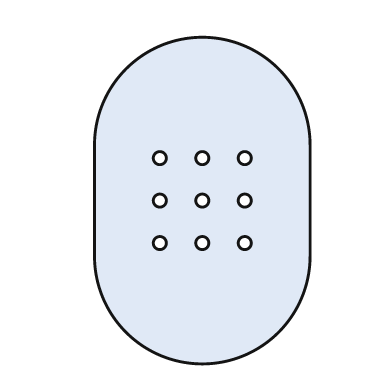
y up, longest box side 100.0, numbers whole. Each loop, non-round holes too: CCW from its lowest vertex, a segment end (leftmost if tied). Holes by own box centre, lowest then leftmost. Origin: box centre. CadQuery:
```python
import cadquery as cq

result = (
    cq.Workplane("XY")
    .moveTo(-33.0, -17.0)
    .threePointArc((0.0, -50.0), (33.0, -17.0))
    .lineTo(33.0, 17.0)
    .threePointArc((0.0, 50.0), (-33.0, 17.0))
    .close()
    .moveTo(-13.0, -13.0)
    .circle(2.0)
    .moveTo(0.0, -13.0)
    .circle(2.0)
    .moveTo(13.0, -13.0)
    .circle(2.0)
    .moveTo(-13.0, 0.0)
    .circle(2.0)
    .moveTo(0.0, 0.0)
    .circle(2.0)
    .moveTo(13.0, 0.0)
    .circle(2.0)
    .moveTo(-13.0, 13.0)
    .circle(2.0)
    .moveTo(0.0, 13.0)
    .circle(2.0)
    .moveTo(13.0, 13.0)
    .circle(2.0)
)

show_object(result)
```